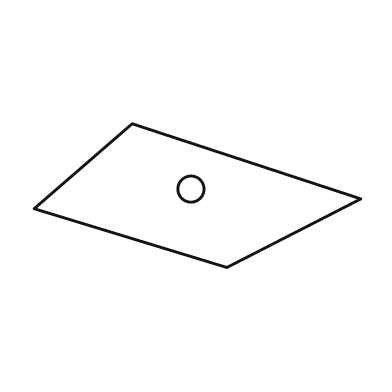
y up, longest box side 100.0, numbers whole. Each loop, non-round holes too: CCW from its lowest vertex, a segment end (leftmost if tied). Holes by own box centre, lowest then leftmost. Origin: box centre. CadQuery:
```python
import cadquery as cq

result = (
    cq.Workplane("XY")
    .moveTo(9.0, -22.0)
    .lineTo(50.0, -1.0)
    .lineTo(-20.0, 22.0)
    .lineTo(-50.0, -4.0)
    .close()
    .moveTo(-2.0, 2.0)
    .circle(4.0)
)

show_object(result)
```